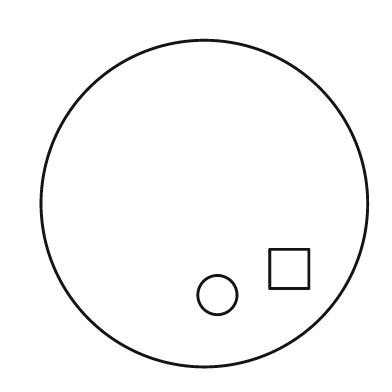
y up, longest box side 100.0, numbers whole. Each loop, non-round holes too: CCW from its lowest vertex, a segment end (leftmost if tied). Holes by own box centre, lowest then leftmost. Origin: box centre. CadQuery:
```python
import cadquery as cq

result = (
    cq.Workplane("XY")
    .moveTo(0.0, 0.0)
    .circle(50.0)
    .moveTo(4.0, -28.0)
    .circle(6.0)
    .moveTo(20.0, -26.0)
    .lineTo(32.0, -26.0)
    .lineTo(32.0, -14.0)
    .lineTo(20.0, -14.0)
    .close()
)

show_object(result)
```